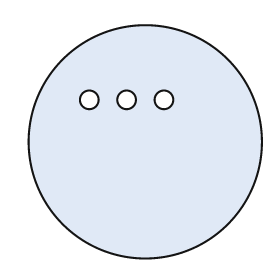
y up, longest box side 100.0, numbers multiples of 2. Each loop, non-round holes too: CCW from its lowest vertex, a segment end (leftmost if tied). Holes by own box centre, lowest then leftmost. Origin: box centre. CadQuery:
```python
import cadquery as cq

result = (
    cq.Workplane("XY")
    .moveTo(0.0, 0.0)
    .circle(50.0)
    .moveTo(-24.0, 18.0)
    .circle(4.0)
    .moveTo(-8.0, 18.0)
    .circle(4.0)
    .moveTo(8.0, 18.0)
    .circle(4.0)
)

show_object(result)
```